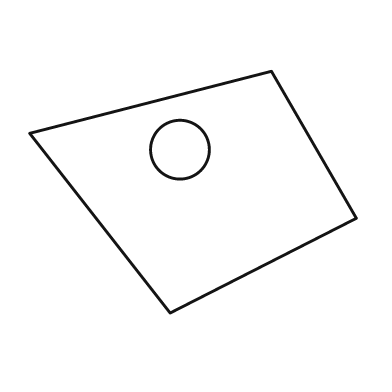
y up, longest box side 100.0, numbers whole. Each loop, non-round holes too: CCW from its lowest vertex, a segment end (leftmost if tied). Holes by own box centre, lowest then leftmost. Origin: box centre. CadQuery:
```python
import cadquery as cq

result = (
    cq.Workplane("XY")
    .moveTo(-7.0, -37.0)
    .lineTo(50.0, -8.0)
    .lineTo(24.0, 37.0)
    .lineTo(-50.0, 18.0)
    .close()
    .moveTo(-4.0, 13.0)
    .circle(9.0)
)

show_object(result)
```